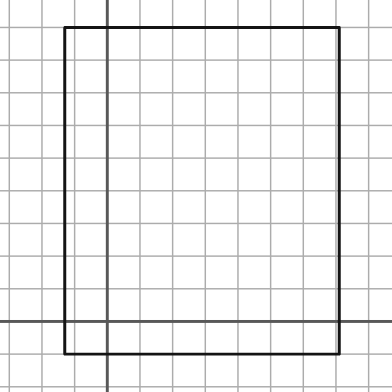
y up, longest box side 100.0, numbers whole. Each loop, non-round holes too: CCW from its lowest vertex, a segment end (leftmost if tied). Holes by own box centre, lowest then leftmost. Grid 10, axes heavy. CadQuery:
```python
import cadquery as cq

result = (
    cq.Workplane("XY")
    .moveTo(-13.0, -10.0)
    .lineTo(71.0, -10.0)
    .lineTo(71.0, 90.0)
    .lineTo(-13.0, 90.0)
    .close()
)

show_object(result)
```